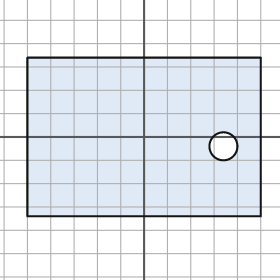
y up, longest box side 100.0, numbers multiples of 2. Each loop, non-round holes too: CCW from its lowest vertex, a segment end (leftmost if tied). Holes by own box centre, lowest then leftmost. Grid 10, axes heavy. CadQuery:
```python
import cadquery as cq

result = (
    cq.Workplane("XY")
    .moveTo(-50.0, -34.0)
    .lineTo(50.0, -34.0)
    .lineTo(50.0, 34.0)
    .lineTo(-50.0, 34.0)
    .close()
    .moveTo(34.0, -4.0)
    .circle(6.0)
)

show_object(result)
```